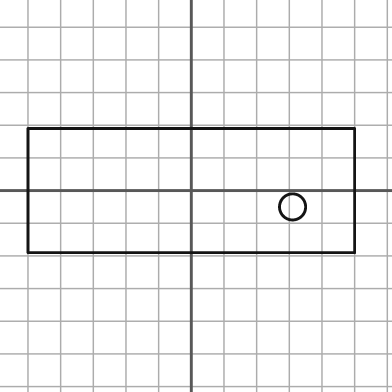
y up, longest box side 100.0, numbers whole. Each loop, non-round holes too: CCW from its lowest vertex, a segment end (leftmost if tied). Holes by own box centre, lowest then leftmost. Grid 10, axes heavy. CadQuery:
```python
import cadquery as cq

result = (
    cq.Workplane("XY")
    .moveTo(-50.0, -19.0)
    .lineTo(50.0, -19.0)
    .lineTo(50.0, 19.0)
    .lineTo(-50.0, 19.0)
    .close()
    .moveTo(31.0, -5.0)
    .circle(4.0)
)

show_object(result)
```